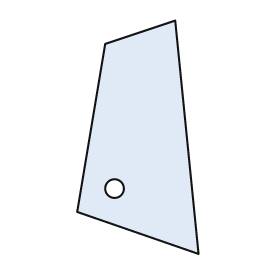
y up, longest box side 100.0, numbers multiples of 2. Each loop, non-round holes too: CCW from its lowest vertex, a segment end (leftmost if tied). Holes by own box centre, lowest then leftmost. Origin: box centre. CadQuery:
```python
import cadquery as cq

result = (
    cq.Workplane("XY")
    .moveTo(26.0, -50.0)
    .lineTo(16.0, 50.0)
    .lineTo(-14.0, 40.0)
    .lineTo(-26.0, -32.0)
    .close()
    .moveTo(-10.0, -22.0)
    .circle(4.0)
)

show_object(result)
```